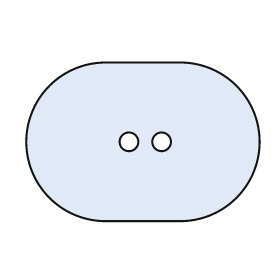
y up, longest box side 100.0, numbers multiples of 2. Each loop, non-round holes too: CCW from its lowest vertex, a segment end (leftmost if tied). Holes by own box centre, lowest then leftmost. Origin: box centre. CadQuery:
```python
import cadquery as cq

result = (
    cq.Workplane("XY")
    .moveTo(-16.0, -34.0)
    .lineTo(16.0, -34.0)
    .threePointArc((50.0, 0.0), (16.0, 34.0))
    .lineTo(-16.0, 34.0)
    .threePointArc((-50.0, 0.0), (-16.0, -34.0))
    .close()
    .moveTo(-6.0, 0.0)
    .circle(4.0)
    .moveTo(8.0, 0.0)
    .circle(4.0)
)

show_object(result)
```